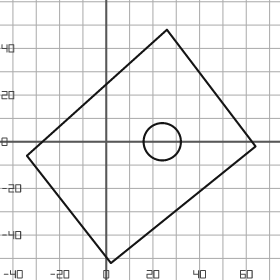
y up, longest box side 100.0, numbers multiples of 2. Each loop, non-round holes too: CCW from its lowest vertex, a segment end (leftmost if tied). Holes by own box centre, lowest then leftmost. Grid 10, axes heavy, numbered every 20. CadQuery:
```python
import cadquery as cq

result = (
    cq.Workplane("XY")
    .moveTo(2.0, -52.0)
    .lineTo(64.0, -2.0)
    .lineTo(26.0, 48.0)
    .lineTo(-34.0, -6.0)
    .close()
    .moveTo(24.0, 0.0)
    .circle(8.0)
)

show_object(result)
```